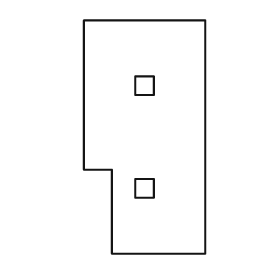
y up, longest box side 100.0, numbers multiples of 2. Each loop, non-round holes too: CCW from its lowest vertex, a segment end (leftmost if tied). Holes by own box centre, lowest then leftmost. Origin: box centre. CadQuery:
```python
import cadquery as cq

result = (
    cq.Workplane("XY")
    .moveTo(-14.0, -50.0)
    .lineTo(26.0, -50.0)
    .lineTo(26.0, 50.0)
    .lineTo(-26.0, 50.0)
    .lineTo(-26.0, -14.0)
    .lineTo(-14.0, -14.0)
    .close()
    .moveTo(-4.0, -26.0)
    .lineTo(4.0, -26.0)
    .lineTo(4.0, -18.0)
    .lineTo(-4.0, -18.0)
    .close()
    .moveTo(-4.0, 18.0)
    .lineTo(4.0, 18.0)
    .lineTo(4.0, 26.0)
    .lineTo(-4.0, 26.0)
    .close()
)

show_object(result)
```